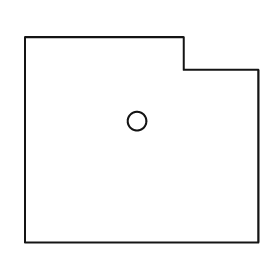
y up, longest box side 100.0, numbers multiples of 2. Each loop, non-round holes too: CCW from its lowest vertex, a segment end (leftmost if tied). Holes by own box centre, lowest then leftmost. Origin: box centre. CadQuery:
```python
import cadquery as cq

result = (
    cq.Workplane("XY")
    .moveTo(-50.0, -44.0)
    .lineTo(50.0, -44.0)
    .lineTo(50.0, 30.0)
    .lineTo(18.0, 30.0)
    .lineTo(18.0, 44.0)
    .lineTo(-50.0, 44.0)
    .close()
    .moveTo(-2.0, 8.0)
    .circle(4.0)
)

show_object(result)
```